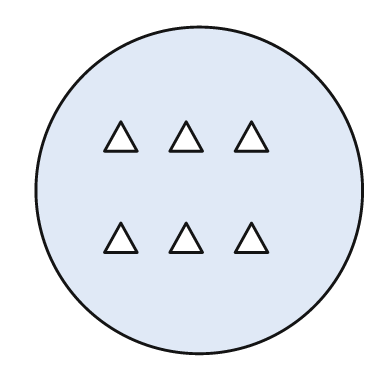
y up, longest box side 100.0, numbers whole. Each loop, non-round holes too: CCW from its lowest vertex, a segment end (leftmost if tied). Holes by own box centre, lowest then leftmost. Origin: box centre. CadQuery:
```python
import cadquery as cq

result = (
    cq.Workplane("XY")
    .moveTo(0.0, 0.0)
    .circle(50.0)
    .moveTo(-29.0, -19.0)
    .lineTo(-19.0, -19.0)
    .lineTo(-24.0, -10.0)
    .close()
    .moveTo(-9.0, -19.0)
    .lineTo(1.0, -19.0)
    .lineTo(-4.0, -10.0)
    .close()
    .moveTo(11.0, -19.0)
    .lineTo(21.0, -19.0)
    .lineTo(16.0, -10.0)
    .close()
    .moveTo(-29.0, 12.0)
    .lineTo(-19.0, 12.0)
    .lineTo(-24.0, 21.0)
    .close()
    .moveTo(-9.0, 12.0)
    .lineTo(1.0, 12.0)
    .lineTo(-4.0, 21.0)
    .close()
    .moveTo(11.0, 12.0)
    .lineTo(21.0, 12.0)
    .lineTo(16.0, 21.0)
    .close()
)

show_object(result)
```